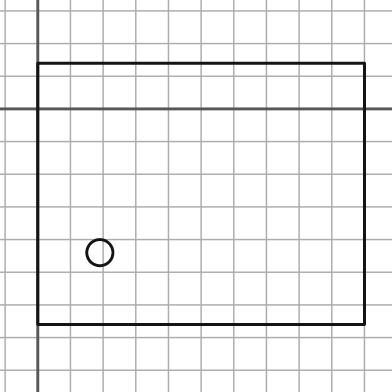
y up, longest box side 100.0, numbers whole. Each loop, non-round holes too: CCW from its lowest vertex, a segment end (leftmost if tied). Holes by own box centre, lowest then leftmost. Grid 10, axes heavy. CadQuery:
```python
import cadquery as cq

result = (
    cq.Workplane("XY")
    .moveTo(0.0, -66.0)
    .lineTo(100.0, -66.0)
    .lineTo(100.0, 14.0)
    .lineTo(0.0, 14.0)
    .close()
    .moveTo(19.0, -44.0)
    .circle(4.0)
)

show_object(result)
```